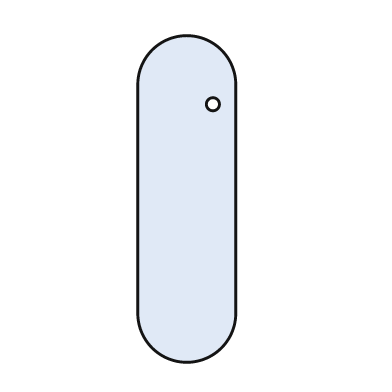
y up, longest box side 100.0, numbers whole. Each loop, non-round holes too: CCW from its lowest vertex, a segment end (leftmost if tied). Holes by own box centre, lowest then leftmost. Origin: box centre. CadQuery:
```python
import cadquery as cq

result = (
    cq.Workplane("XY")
    .moveTo(-15.0, -35.0)
    .threePointArc((0.0, -50.0), (15.0, -35.0))
    .lineTo(15.0, 35.0)
    .threePointArc((0.0, 50.0), (-15.0, 35.0))
    .close()
    .moveTo(8.0, 29.0)
    .circle(2.0)
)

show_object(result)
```